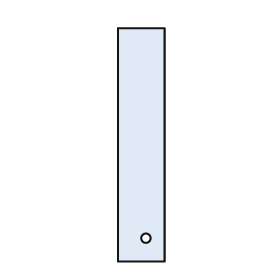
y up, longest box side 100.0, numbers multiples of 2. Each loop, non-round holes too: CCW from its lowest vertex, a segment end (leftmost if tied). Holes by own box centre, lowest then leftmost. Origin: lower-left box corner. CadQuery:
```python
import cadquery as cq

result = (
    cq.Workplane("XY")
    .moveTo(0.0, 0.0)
    .lineTo(20.0, 0.0)
    .lineTo(20.0, 100.0)
    .lineTo(0.0, 100.0)
    .close()
    .moveTo(12.0, 10.0)
    .circle(2.0)
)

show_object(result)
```